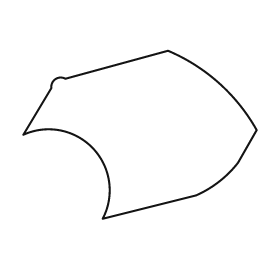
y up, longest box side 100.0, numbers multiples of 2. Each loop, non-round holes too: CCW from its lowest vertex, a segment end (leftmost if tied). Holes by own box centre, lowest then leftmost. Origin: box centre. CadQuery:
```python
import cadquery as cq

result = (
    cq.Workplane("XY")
    .moveTo(-16.0, -36.0)
    .lineTo(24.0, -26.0)
    .threePointArc((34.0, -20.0), (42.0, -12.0))
    .lineTo(50.0, 2.0)
    .threePointArc((34.0, 22.0), (12.0, 36.0))
    .lineTo(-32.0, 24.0)
    .threePointArc((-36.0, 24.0), (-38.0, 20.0))
    .lineTo(-50.0, 0.0)
    .threePointArc((-20.0, -6.0), (-16.0, -36.0))
    .close()
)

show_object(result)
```